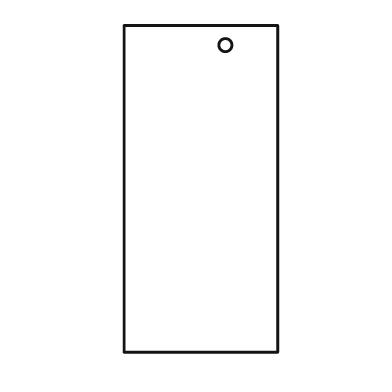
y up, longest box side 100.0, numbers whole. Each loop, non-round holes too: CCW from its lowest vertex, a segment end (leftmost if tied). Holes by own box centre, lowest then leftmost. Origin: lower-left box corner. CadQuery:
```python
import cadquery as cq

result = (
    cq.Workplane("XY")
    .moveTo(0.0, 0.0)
    .lineTo(47.0, 0.0)
    .lineTo(47.0, 100.0)
    .lineTo(0.0, 100.0)
    .close()
    .moveTo(31.0, 94.0)
    .circle(2.0)
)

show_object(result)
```